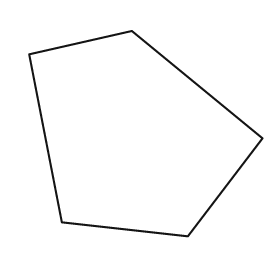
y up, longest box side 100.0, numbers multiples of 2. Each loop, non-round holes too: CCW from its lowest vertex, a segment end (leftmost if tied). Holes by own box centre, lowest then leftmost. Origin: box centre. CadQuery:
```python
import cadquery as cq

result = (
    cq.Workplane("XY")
    .moveTo(18.0, -44.0)
    .lineTo(50.0, -2.0)
    .lineTo(-6.0, 44.0)
    .lineTo(-50.0, 34.0)
    .lineTo(-36.0, -38.0)
    .close()
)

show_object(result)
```